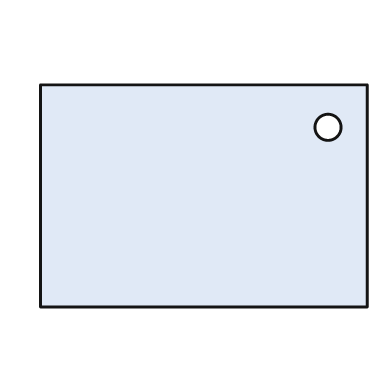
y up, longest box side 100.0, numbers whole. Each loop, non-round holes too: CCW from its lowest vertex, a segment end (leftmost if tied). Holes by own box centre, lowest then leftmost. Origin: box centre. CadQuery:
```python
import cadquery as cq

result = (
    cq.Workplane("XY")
    .moveTo(-50.0, -34.0)
    .lineTo(50.0, -34.0)
    .lineTo(50.0, 34.0)
    .lineTo(-50.0, 34.0)
    .close()
    .moveTo(38.0, 21.0)
    .circle(4.0)
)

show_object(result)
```